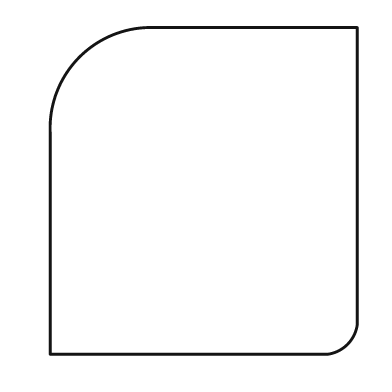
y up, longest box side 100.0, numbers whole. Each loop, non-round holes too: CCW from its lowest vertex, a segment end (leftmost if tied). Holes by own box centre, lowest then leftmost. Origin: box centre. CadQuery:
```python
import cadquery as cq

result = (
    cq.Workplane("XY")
    .moveTo(-47.0, -50.0)
    .lineTo(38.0, -50.0)
    .threePointArc((44.0, -47.0), (47.0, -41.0))
    .lineTo(47.0, 50.0)
    .lineTo(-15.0, 50.0)
    .threePointArc((-38.0, 41.0), (-47.0, 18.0))
    .close()
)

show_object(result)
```